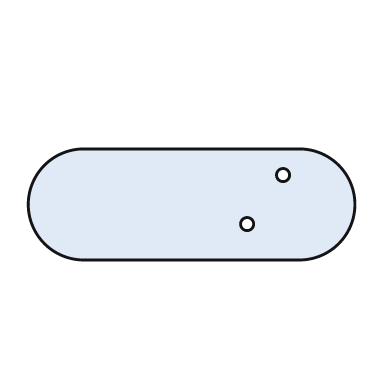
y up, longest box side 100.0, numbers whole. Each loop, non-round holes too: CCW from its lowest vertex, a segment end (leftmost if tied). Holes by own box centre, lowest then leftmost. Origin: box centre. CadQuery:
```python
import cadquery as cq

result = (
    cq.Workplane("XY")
    .moveTo(-33.0, -17.0)
    .lineTo(33.0, -17.0)
    .threePointArc((50.0, 0.0), (33.0, 17.0))
    .lineTo(-33.0, 17.0)
    .threePointArc((-50.0, 0.0), (-33.0, -17.0))
    .close()
    .moveTo(17.0, -6.0)
    .circle(2.0)
    .moveTo(28.0, 9.0)
    .circle(2.0)
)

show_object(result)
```